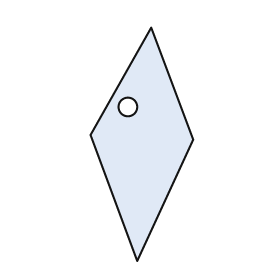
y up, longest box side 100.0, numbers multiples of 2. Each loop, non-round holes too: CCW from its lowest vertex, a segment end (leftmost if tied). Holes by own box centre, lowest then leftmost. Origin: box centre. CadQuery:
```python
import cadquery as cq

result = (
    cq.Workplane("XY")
    .moveTo(-2.0, -50.0)
    .lineTo(22.0, 2.0)
    .lineTo(4.0, 50.0)
    .lineTo(-22.0, 4.0)
    .close()
    .moveTo(-6.0, 16.0)
    .circle(4.0)
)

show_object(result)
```